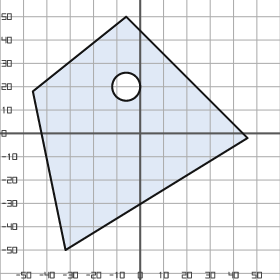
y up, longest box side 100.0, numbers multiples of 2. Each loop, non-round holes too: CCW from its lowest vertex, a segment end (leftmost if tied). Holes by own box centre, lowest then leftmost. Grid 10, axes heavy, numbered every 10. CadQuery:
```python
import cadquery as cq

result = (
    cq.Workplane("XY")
    .moveTo(-32.0, -50.0)
    .lineTo(46.0, -2.0)
    .lineTo(-6.0, 50.0)
    .lineTo(-46.0, 18.0)
    .close()
    .moveTo(-6.0, 20.0)
    .circle(6.0)
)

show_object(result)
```